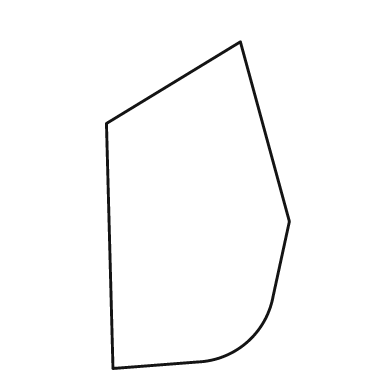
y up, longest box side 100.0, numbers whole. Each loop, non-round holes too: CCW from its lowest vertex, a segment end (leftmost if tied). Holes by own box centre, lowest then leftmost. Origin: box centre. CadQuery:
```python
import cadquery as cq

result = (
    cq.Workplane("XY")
    .moveTo(-26.0, -50.0)
    .lineTo(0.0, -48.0)
    .threePointArc((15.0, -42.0), (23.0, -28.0))
    .lineTo(28.0, -5.0)
    .lineTo(13.0, 50.0)
    .lineTo(-28.0, 25.0)
    .close()
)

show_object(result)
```